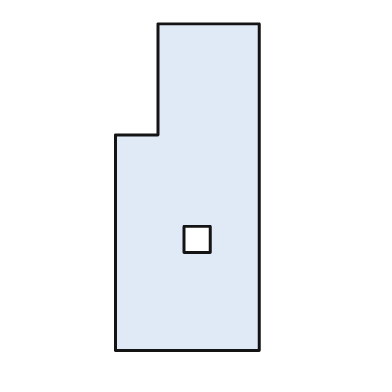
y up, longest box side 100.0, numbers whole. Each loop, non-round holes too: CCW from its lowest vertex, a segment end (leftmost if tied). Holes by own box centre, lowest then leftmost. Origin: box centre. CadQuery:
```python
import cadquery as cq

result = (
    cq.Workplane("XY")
    .moveTo(-22.0, -50.0)
    .lineTo(22.0, -50.0)
    .lineTo(22.0, 50.0)
    .lineTo(-9.0, 50.0)
    .lineTo(-9.0, 16.0)
    .lineTo(-22.0, 16.0)
    .close()
    .moveTo(-1.0, -20.0)
    .lineTo(7.0, -20.0)
    .lineTo(7.0, -12.0)
    .lineTo(-1.0, -12.0)
    .close()
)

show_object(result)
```